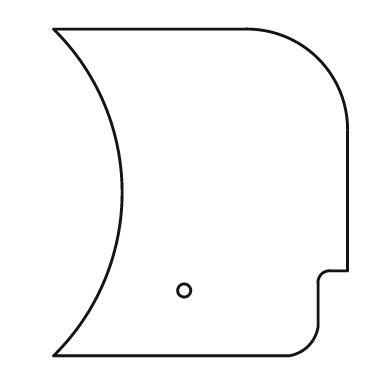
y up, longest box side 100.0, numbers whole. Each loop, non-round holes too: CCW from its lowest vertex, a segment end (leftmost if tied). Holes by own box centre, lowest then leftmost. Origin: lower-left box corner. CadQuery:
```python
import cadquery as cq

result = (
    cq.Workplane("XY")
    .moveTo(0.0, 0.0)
    .lineTo(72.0, 0.0)
    .threePointArc((78.0, 3.0), (81.0, 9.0))
    .lineTo(81.0, 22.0)
    .threePointArc((82.0, 25.0), (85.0, 26.0))
    .lineTo(90.0, 26.0)
    .lineTo(90.0, 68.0)
    .threePointArc((81.0, 91.0), (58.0, 100.0))
    .lineTo(0.0, 100.0)
    .threePointArc((21.0, 50.0), (0.0, 0.0))
    .close()
    .moveTo(40.0, 20.0)
    .circle(2.0)
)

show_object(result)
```